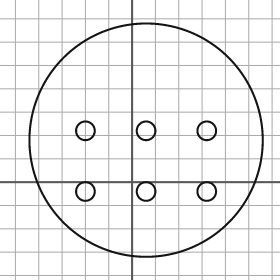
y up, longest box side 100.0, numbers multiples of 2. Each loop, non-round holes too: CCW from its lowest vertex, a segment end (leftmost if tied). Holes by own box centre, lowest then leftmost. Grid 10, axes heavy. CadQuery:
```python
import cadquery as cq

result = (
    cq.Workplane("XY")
    .moveTo(6.0, 18.0)
    .circle(50.0)
    .moveTo(-20.0, -4.0)
    .circle(4.0)
    .moveTo(6.0, -4.0)
    .circle(4.0)
    .moveTo(32.0, -4.0)
    .circle(4.0)
    .moveTo(-20.0, 22.0)
    .circle(4.0)
    .moveTo(6.0, 22.0)
    .circle(4.0)
    .moveTo(32.0, 22.0)
    .circle(4.0)
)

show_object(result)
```